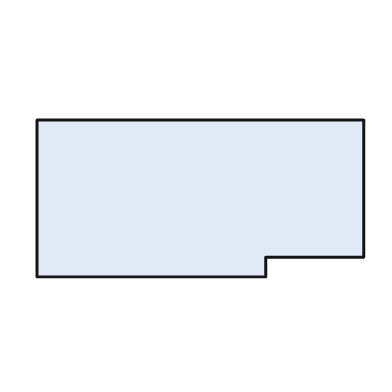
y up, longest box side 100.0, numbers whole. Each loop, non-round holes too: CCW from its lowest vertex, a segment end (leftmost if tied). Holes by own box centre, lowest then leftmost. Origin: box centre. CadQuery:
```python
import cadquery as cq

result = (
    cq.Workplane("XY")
    .moveTo(-50.0, -24.0)
    .lineTo(20.0, -24.0)
    .lineTo(20.0, -18.0)
    .lineTo(50.0, -18.0)
    .lineTo(50.0, 24.0)
    .lineTo(-50.0, 24.0)
    .close()
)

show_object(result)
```